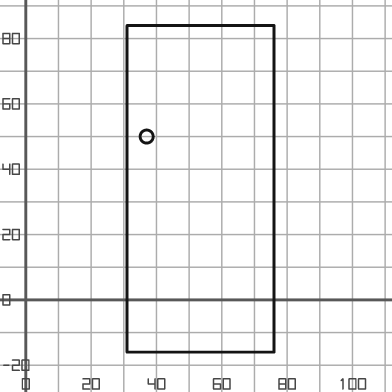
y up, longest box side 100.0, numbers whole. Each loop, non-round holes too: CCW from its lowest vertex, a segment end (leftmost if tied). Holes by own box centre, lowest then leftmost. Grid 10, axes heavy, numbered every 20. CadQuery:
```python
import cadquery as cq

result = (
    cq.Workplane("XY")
    .moveTo(31.0, -16.0)
    .lineTo(76.0, -16.0)
    .lineTo(76.0, 84.0)
    .lineTo(31.0, 84.0)
    .close()
    .moveTo(37.0, 50.0)
    .circle(2.0)
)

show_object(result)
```